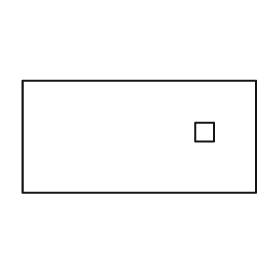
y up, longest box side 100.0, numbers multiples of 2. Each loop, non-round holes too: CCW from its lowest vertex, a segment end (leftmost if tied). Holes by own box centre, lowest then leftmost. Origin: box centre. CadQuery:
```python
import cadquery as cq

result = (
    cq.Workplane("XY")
    .moveTo(-50.0, -24.0)
    .lineTo(50.0, -24.0)
    .lineTo(50.0, 24.0)
    .lineTo(-50.0, 24.0)
    .close()
    .moveTo(24.0, -2.0)
    .lineTo(32.0, -2.0)
    .lineTo(32.0, 6.0)
    .lineTo(24.0, 6.0)
    .close()
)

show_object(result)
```